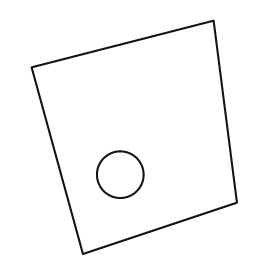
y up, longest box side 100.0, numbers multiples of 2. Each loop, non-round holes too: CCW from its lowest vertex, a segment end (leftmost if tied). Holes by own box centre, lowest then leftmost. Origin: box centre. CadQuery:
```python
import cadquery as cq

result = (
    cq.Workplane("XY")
    .moveTo(-22.0, -50.0)
    .lineTo(44.0, -28.0)
    .lineTo(34.0, 50.0)
    .lineTo(-44.0, 30.0)
    .close()
    .moveTo(-6.0, -16.0)
    .circle(10.0)
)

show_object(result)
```